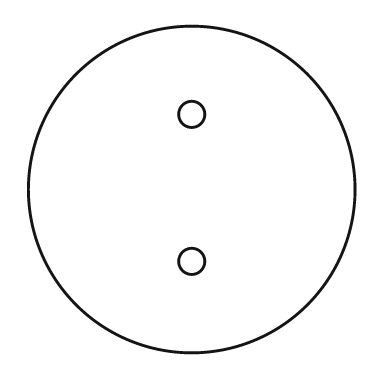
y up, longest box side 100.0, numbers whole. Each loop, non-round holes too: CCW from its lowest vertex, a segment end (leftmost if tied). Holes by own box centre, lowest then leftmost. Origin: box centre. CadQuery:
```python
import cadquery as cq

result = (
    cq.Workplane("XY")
    .moveTo(0.0, 0.0)
    .circle(50.0)
    .moveTo(0.0, -22.0)
    .circle(4.0)
    .moveTo(0.0, 23.0)
    .circle(4.0)
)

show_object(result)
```